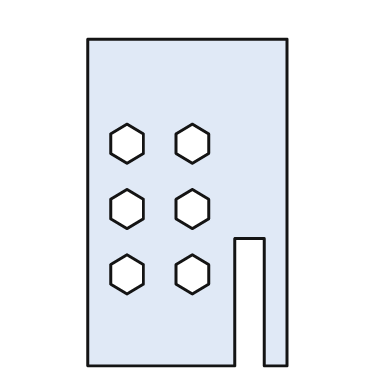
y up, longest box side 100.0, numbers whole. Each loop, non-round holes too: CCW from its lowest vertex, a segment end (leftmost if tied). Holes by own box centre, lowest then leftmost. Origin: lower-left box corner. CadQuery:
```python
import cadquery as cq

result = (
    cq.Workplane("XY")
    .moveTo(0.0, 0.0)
    .lineTo(45.0, 0.0)
    .lineTo(45.0, 39.0)
    .lineTo(54.0, 39.0)
    .lineTo(54.0, 0.0)
    .lineTo(61.0, 0.0)
    .lineTo(61.0, 100.0)
    .lineTo(0.0, 100.0)
    .close()
    .moveTo(12.0, 22.0)
    .lineTo(17.0, 25.0)
    .lineTo(17.0, 31.0)
    .lineTo(12.0, 34.0)
    .lineTo(7.0, 31.0)
    .lineTo(7.0, 25.0)
    .close()
    .moveTo(32.0, 22.0)
    .lineTo(37.0, 25.0)
    .lineTo(37.0, 31.0)
    .lineTo(32.0, 34.0)
    .lineTo(27.0, 31.0)
    .lineTo(27.0, 25.0)
    .close()
    .moveTo(12.0, 42.0)
    .lineTo(17.0, 45.0)
    .lineTo(17.0, 51.0)
    .lineTo(12.0, 54.0)
    .lineTo(7.0, 51.0)
    .lineTo(7.0, 45.0)
    .close()
    .moveTo(32.0, 42.0)
    .lineTo(37.0, 45.0)
    .lineTo(37.0, 51.0)
    .lineTo(32.0, 54.0)
    .lineTo(27.0, 51.0)
    .lineTo(27.0, 45.0)
    .close()
    .moveTo(12.0, 62.0)
    .lineTo(17.0, 65.0)
    .lineTo(17.0, 71.0)
    .lineTo(12.0, 74.0)
    .lineTo(7.0, 71.0)
    .lineTo(7.0, 65.0)
    .close()
    .moveTo(32.0, 62.0)
    .lineTo(37.0, 65.0)
    .lineTo(37.0, 71.0)
    .lineTo(32.0, 74.0)
    .lineTo(27.0, 71.0)
    .lineTo(27.0, 65.0)
    .close()
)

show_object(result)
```